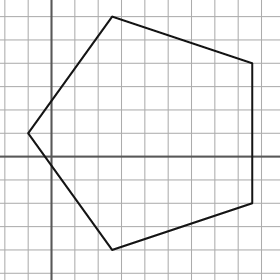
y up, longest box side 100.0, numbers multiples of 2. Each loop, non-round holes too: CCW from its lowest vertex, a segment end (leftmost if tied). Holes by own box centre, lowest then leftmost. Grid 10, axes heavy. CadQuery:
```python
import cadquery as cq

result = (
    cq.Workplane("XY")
    .moveTo(26.0, -40.0)
    .lineTo(86.0, -20.0)
    .lineTo(86.0, 40.0)
    .lineTo(26.0, 60.0)
    .lineTo(-10.0, 10.0)
    .close()
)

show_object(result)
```